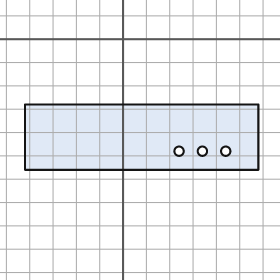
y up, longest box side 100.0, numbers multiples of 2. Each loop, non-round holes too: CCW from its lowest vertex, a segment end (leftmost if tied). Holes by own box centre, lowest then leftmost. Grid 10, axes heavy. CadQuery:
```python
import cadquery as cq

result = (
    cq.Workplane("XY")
    .moveTo(-42.0, -56.0)
    .lineTo(58.0, -56.0)
    .lineTo(58.0, -28.0)
    .lineTo(-42.0, -28.0)
    .close()
    .moveTo(24.0, -48.0)
    .circle(2.0)
    .moveTo(34.0, -48.0)
    .circle(2.0)
    .moveTo(44.0, -48.0)
    .circle(2.0)
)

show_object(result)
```